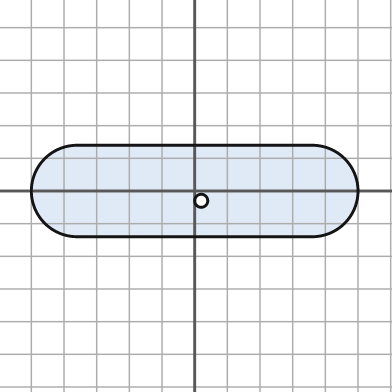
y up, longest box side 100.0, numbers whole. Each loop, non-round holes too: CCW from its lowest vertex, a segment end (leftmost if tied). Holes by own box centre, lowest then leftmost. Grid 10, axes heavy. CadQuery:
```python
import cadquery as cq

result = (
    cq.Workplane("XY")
    .moveTo(-36.0, -14.0)
    .lineTo(36.0, -14.0)
    .threePointArc((50.0, 0.0), (36.0, 14.0))
    .lineTo(-36.0, 14.0)
    .threePointArc((-50.0, 0.0), (-36.0, -14.0))
    .close()
    .moveTo(2.0, -3.0)
    .circle(2.0)
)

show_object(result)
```